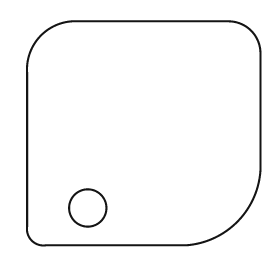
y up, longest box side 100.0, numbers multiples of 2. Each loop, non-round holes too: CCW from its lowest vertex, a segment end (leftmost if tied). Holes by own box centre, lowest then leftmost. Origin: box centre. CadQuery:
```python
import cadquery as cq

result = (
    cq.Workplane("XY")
    .moveTo(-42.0, -48.0)
    .lineTo(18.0, -48.0)
    .threePointArc((40.0, -38.0), (50.0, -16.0))
    .lineTo(50.0, 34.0)
    .threePointArc((46.0, 44.0), (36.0, 48.0))
    .lineTo(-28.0, 48.0)
    .threePointArc((-44.0, 42.0), (-50.0, 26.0))
    .lineTo(-50.0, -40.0)
    .threePointArc((-48.0, -46.0), (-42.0, -48.0))
    .close()
    .moveTo(-24.0, -32.0)
    .circle(8.0)
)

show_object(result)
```